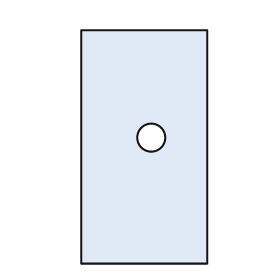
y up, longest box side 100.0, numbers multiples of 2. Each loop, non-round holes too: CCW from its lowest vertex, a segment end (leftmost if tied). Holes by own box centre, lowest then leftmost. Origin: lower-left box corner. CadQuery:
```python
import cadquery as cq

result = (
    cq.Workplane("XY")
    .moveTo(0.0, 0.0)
    .lineTo(54.0, 0.0)
    .lineTo(54.0, 100.0)
    .lineTo(0.0, 100.0)
    .close()
    .moveTo(30.0, 54.0)
    .circle(6.0)
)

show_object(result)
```